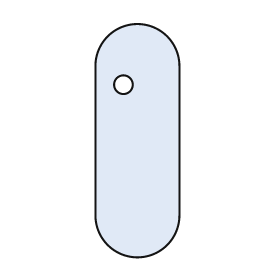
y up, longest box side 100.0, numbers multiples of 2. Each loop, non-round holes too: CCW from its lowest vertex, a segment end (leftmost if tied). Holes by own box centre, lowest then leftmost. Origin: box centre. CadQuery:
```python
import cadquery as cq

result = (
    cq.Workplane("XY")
    .moveTo(-18.0, -32.0)
    .threePointArc((0.0, -50.0), (18.0, -32.0))
    .lineTo(18.0, 32.0)
    .threePointArc((0.0, 50.0), (-18.0, 32.0))
    .close()
    .moveTo(-6.0, 24.0)
    .circle(4.0)
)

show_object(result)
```